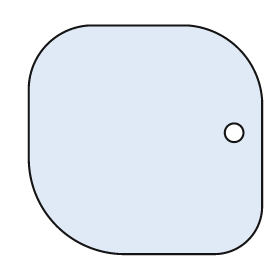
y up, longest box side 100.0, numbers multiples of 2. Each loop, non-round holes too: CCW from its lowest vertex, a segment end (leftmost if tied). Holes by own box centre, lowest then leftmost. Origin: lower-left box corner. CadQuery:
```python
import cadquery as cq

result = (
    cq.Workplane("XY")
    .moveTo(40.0, 0.0)
    .lineTo(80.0, 0.0)
    .threePointArc((94.0, 6.0), (100.0, 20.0))
    .lineTo(100.0, 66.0)
    .threePointArc((90.0, 88.0), (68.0, 98.0))
    .lineTo(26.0, 98.0)
    .threePointArc((8.0, 90.0), (0.0, 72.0))
    .lineTo(0.0, 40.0)
    .threePointArc((12.0, 12.0), (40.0, 0.0))
    .close()
    .moveTo(88.0, 52.0)
    .circle(4.0)
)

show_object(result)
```